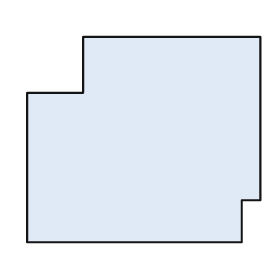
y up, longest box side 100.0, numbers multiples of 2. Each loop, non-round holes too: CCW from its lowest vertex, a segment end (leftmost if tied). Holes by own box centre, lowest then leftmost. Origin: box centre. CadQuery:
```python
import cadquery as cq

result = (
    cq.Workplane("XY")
    .moveTo(-50.0, -44.0)
    .lineTo(42.0, -44.0)
    .lineTo(42.0, -26.0)
    .lineTo(50.0, -26.0)
    .lineTo(50.0, 44.0)
    .lineTo(-26.0, 44.0)
    .lineTo(-26.0, 20.0)
    .lineTo(-50.0, 20.0)
    .close()
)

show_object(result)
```